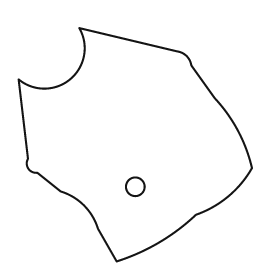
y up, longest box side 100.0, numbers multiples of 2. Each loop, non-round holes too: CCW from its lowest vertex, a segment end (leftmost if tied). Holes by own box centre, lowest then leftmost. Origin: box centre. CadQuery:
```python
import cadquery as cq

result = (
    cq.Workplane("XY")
    .moveTo(-8.0, -50.0)
    .threePointArc((10.0, -42.0), (26.0, -30.0))
    .threePointArc((40.0, -22.0), (50.0, -10.0))
    .threePointArc((44.0, 6.0), (34.0, 20.0))
    .lineTo(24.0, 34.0)
    .threePointArc((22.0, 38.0), (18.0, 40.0))
    .lineTo(-24.0, 50.0)
    .threePointArc((-28.0, 28.0), (-50.0, 28.0))
    .lineTo(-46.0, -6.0)
    .threePointArc((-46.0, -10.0), (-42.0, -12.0))
    .lineTo(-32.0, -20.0)
    .threePointArc((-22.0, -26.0), (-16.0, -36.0))
    .close()
    .moveTo(0.0, -18.0)
    .circle(4.0)
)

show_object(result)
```